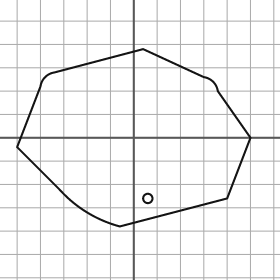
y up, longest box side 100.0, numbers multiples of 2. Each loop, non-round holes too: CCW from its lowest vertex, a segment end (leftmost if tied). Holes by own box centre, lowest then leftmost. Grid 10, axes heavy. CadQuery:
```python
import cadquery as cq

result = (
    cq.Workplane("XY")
    .moveTo(-6.0, -38.0)
    .lineTo(40.0, -26.0)
    .lineTo(50.0, 0.0)
    .lineTo(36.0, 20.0)
    .threePointArc((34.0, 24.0), (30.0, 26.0))
    .lineTo(4.0, 38.0)
    .lineTo(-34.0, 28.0)
    .threePointArc((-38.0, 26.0), (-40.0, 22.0))
    .lineTo(-50.0, -4.0)
    .lineTo(-32.0, -22.0)
    .threePointArc((-20.0, -32.0), (-6.0, -38.0))
    .close()
    .moveTo(6.0, -26.0)
    .circle(2.0)
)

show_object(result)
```